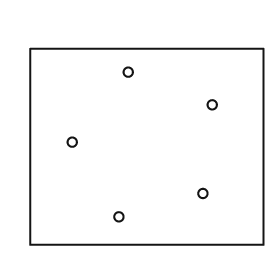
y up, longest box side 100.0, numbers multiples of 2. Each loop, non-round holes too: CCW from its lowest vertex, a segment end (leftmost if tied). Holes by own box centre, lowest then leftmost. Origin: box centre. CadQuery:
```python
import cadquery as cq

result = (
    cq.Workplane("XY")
    .moveTo(-50.0, -42.0)
    .lineTo(50.0, -42.0)
    .lineTo(50.0, 42.0)
    .lineTo(-50.0, 42.0)
    .close()
    .moveTo(-12.0, -30.0)
    .circle(2.0)
    .moveTo(24.0, -20.0)
    .circle(2.0)
    .moveTo(-32.0, 2.0)
    .circle(2.0)
    .moveTo(28.0, 18.0)
    .circle(2.0)
    .moveTo(-8.0, 32.0)
    .circle(2.0)
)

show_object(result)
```